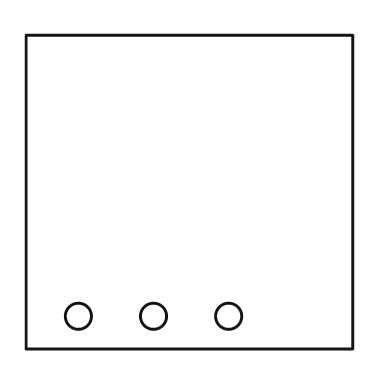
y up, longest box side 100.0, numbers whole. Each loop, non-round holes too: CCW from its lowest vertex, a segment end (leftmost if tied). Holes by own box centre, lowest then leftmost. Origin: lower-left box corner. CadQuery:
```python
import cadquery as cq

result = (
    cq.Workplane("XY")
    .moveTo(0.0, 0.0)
    .lineTo(100.0, 0.0)
    .lineTo(100.0, 96.0)
    .lineTo(0.0, 96.0)
    .close()
    .moveTo(16.0, 10.0)
    .circle(4.0)
    .moveTo(39.0, 10.0)
    .circle(4.0)
    .moveTo(62.0, 10.0)
    .circle(4.0)
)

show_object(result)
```